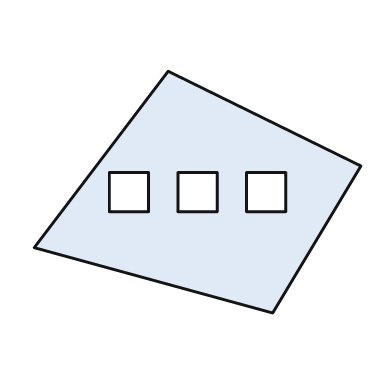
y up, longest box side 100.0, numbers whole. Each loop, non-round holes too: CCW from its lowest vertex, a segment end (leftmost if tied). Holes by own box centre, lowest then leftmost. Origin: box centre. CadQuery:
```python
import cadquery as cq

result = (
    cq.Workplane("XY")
    .moveTo(23.0, -37.0)
    .lineTo(50.0, 8.0)
    .lineTo(-9.0, 37.0)
    .lineTo(-50.0, -17.0)
    .close()
    .moveTo(-27.0, -6.0)
    .lineTo(-15.0, -6.0)
    .lineTo(-15.0, 6.0)
    .lineTo(-27.0, 6.0)
    .close()
    .moveTo(-6.0, -6.0)
    .lineTo(6.0, -6.0)
    .lineTo(6.0, 6.0)
    .lineTo(-6.0, 6.0)
    .close()
    .moveTo(15.0, -6.0)
    .lineTo(27.0, -6.0)
    .lineTo(27.0, 6.0)
    .lineTo(15.0, 6.0)
    .close()
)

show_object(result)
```